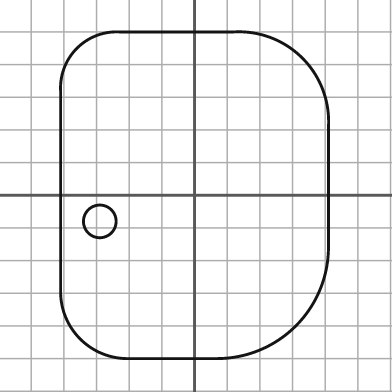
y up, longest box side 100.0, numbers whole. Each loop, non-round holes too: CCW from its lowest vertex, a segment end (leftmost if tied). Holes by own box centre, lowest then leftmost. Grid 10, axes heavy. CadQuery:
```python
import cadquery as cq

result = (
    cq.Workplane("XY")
    .moveTo(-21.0, -50.0)
    .lineTo(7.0, -50.0)
    .threePointArc((31.0, -40.0), (41.0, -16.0))
    .lineTo(41.0, 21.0)
    .threePointArc((33.0, 42.0), (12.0, 50.0))
    .lineTo(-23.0, 50.0)
    .threePointArc((-36.0, 45.0), (-41.0, 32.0))
    .lineTo(-41.0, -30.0)
    .threePointArc((-35.0, -44.0), (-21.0, -50.0))
    .close()
    .moveTo(-29.0, -8.0)
    .circle(5.0)
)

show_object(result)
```